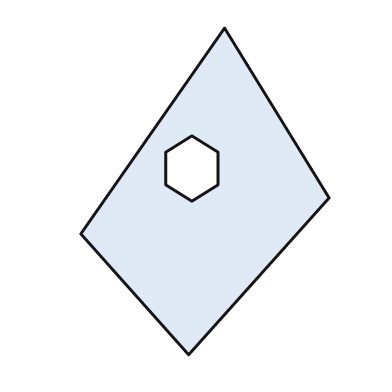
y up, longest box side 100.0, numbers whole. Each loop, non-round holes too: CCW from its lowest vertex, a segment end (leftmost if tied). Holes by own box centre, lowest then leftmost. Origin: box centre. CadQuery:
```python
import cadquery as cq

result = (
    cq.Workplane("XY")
    .moveTo(-5.0, -50.0)
    .lineTo(38.0, -2.0)
    .lineTo(6.0, 50.0)
    .lineTo(-38.0, -13.0)
    .close()
    .moveTo(-4.0, -3.0)
    .lineTo(4.0, 2.0)
    .lineTo(4.0, 12.0)
    .lineTo(-4.0, 17.0)
    .lineTo(-12.0, 12.0)
    .lineTo(-12.0, 2.0)
    .close()
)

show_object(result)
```